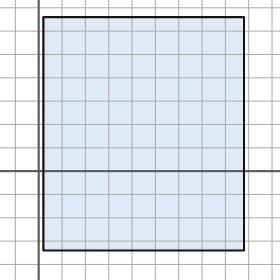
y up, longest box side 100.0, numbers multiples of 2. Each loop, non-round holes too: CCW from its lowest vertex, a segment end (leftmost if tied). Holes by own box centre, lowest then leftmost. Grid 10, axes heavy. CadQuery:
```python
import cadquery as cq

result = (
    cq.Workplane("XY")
    .moveTo(2.0, -34.0)
    .lineTo(88.0, -34.0)
    .lineTo(88.0, 66.0)
    .lineTo(2.0, 66.0)
    .close()
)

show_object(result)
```